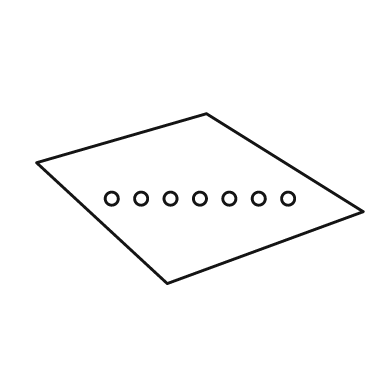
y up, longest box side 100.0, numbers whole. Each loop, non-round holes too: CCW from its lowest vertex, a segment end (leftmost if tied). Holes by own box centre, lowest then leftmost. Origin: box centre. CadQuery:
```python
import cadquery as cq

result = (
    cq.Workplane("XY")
    .moveTo(-10.0, -26.0)
    .lineTo(50.0, -4.0)
    .lineTo(2.0, 26.0)
    .lineTo(-50.0, 11.0)
    .close()
    .moveTo(-27.0, 0.0)
    .circle(2.0)
    .moveTo(-18.0, 0.0)
    .circle(2.0)
    .moveTo(-9.0, 0.0)
    .circle(2.0)
    .moveTo(0.0, 0.0)
    .circle(2.0)
    .moveTo(9.0, 0.0)
    .circle(2.0)
    .moveTo(18.0, 0.0)
    .circle(2.0)
    .moveTo(27.0, 0.0)
    .circle(2.0)
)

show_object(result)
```